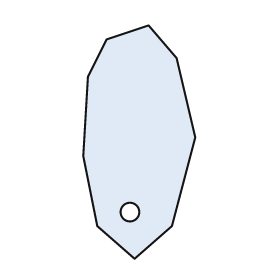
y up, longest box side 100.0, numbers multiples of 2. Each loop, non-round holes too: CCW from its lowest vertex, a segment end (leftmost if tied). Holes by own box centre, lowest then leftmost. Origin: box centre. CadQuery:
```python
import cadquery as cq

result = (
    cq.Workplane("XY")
    .moveTo(-2.0, -50.0)
    .lineTo(14.0, -36.0)
    .lineTo(24.0, 2.0)
    .lineTo(16.0, 36.0)
    .lineTo(4.0, 50.0)
    .lineTo(-14.0, 44.0)
    .lineTo(-22.0, 28.0)
    .lineTo(-24.0, -6.0)
    .lineTo(-18.0, -36.0)
    .close()
    .moveTo(-4.0, -30.0)
    .circle(4.0)
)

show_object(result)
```